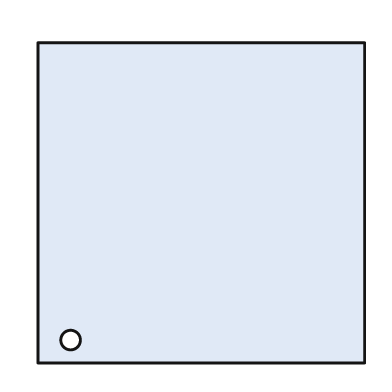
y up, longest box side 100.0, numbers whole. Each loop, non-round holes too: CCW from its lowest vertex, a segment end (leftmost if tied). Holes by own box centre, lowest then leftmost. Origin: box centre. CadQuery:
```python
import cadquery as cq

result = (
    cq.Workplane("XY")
    .moveTo(-50.0, -49.0)
    .lineTo(50.0, -49.0)
    .lineTo(50.0, 49.0)
    .lineTo(-50.0, 49.0)
    .close()
    .moveTo(-40.0, -42.0)
    .circle(3.0)
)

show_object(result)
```